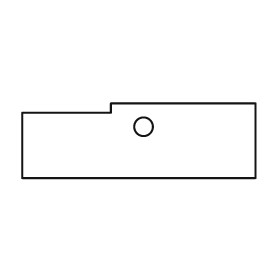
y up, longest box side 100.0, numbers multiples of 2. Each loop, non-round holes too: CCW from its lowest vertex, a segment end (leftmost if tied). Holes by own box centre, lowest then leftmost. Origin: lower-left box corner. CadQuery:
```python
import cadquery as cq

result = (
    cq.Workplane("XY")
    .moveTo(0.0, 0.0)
    .lineTo(100.0, 0.0)
    .lineTo(100.0, 32.0)
    .lineTo(38.0, 32.0)
    .lineTo(38.0, 28.0)
    .lineTo(0.0, 28.0)
    .close()
    .moveTo(52.0, 22.0)
    .circle(4.0)
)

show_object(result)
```